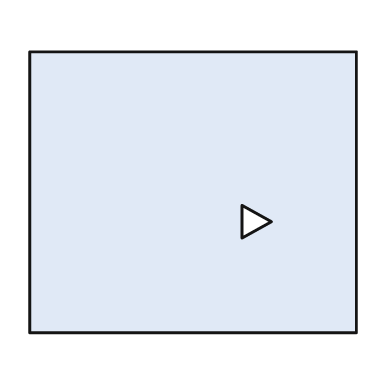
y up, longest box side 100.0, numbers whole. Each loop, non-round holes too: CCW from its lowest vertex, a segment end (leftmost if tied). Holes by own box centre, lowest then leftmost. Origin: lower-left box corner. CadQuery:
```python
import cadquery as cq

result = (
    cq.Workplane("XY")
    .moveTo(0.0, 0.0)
    .lineTo(100.0, 0.0)
    .lineTo(100.0, 86.0)
    .lineTo(0.0, 86.0)
    .close()
    .moveTo(65.0, 29.0)
    .lineTo(74.0, 34.0)
    .lineTo(65.0, 39.0)
    .close()
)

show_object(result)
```